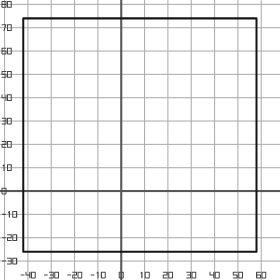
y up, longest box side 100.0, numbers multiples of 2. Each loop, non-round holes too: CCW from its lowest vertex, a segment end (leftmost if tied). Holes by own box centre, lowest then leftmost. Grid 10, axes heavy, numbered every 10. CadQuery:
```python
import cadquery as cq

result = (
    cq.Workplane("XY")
    .moveTo(-42.0, -26.0)
    .lineTo(58.0, -26.0)
    .lineTo(58.0, 74.0)
    .lineTo(-42.0, 74.0)
    .close()
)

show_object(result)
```